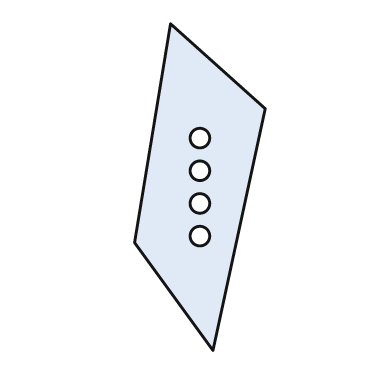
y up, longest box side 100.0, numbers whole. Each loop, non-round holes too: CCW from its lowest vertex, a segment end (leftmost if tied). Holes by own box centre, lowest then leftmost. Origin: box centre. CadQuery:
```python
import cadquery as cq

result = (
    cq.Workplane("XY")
    .moveTo(4.0, -50.0)
    .lineTo(20.0, 24.0)
    .lineTo(-9.0, 50.0)
    .lineTo(-20.0, -17.0)
    .close()
    .moveTo(0.0, -15.0)
    .circle(3.0)
    .moveTo(0.0, -5.0)
    .circle(3.0)
    .moveTo(0.0, 5.0)
    .circle(3.0)
    .moveTo(0.0, 15.0)
    .circle(3.0)
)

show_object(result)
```